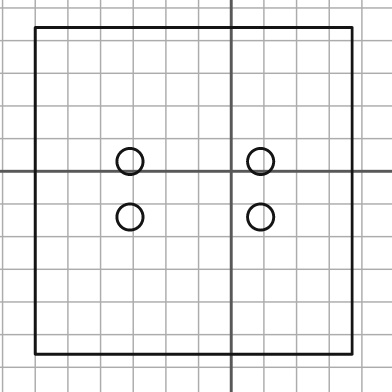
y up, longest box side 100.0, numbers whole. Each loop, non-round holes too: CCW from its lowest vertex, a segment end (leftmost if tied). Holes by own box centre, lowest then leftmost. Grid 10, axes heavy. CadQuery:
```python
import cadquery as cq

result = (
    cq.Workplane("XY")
    .moveTo(-60.0, -56.0)
    .lineTo(37.0, -56.0)
    .lineTo(37.0, 44.0)
    .lineTo(-60.0, 44.0)
    .close()
    .moveTo(-31.0, -14.0)
    .circle(4.0)
    .moveTo(9.0, -14.0)
    .circle(4.0)
    .moveTo(-31.0, 3.0)
    .circle(4.0)
    .moveTo(9.0, 3.0)
    .circle(4.0)
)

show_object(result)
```